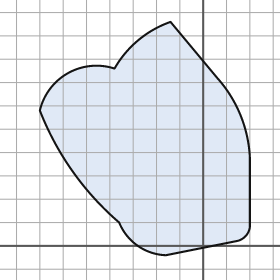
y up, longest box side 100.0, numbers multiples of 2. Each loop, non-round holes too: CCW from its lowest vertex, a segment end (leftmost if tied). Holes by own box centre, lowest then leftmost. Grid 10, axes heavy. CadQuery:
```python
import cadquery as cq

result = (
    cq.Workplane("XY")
    .moveTo(-16.0, -4.0)
    .lineTo(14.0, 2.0)
    .threePointArc((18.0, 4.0), (20.0, 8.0))
    .lineTo(20.0, 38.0)
    .threePointArc((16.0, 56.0), (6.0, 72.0))
    .lineTo(-14.0, 96.0)
    .threePointArc((-28.0, 88.0), (-38.0, 76.0))
    .threePointArc((-58.0, 74.0), (-70.0, 58.0))
    .threePointArc((-56.0, 32.0), (-36.0, 10.0))
    .threePointArc((-28.0, 0.0), (-16.0, -4.0))
    .close()
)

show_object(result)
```